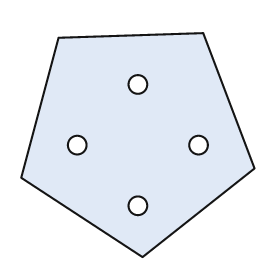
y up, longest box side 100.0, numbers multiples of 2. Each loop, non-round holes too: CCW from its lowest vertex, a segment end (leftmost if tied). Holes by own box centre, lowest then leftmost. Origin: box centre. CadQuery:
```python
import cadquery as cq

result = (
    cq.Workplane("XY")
    .moveTo(2.0, -48.0)
    .lineTo(50.0, -10.0)
    .lineTo(28.0, 48.0)
    .lineTo(-34.0, 46.0)
    .lineTo(-50.0, -14.0)
    .close()
    .moveTo(0.0, -26.0)
    .circle(4.0)
    .moveTo(-26.0, 0.0)
    .circle(4.0)
    .moveTo(26.0, 0.0)
    .circle(4.0)
    .moveTo(0.0, 26.0)
    .circle(4.0)
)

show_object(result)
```